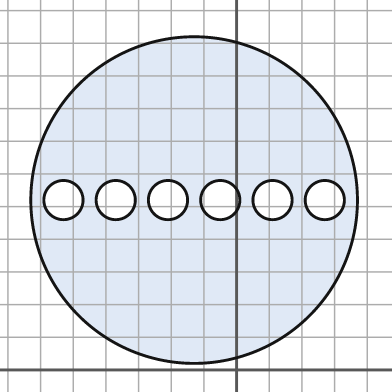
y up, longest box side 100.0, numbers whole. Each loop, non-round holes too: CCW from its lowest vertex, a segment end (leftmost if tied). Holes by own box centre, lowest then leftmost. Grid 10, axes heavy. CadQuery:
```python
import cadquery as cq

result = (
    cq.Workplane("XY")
    .moveTo(-13.0, 52.0)
    .circle(50.0)
    .moveTo(-53.0, 52.0)
    .circle(6.0)
    .moveTo(-37.0, 52.0)
    .circle(6.0)
    .moveTo(-21.0, 52.0)
    .circle(6.0)
    .moveTo(-5.0, 52.0)
    .circle(6.0)
    .moveTo(11.0, 52.0)
    .circle(6.0)
    .moveTo(27.0, 52.0)
    .circle(6.0)
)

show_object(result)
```